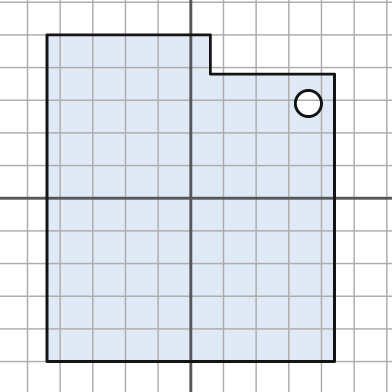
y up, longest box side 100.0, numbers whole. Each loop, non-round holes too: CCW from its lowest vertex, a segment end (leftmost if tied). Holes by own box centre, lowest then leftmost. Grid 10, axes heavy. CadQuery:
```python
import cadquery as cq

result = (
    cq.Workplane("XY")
    .moveTo(-44.0, -50.0)
    .lineTo(44.0, -50.0)
    .lineTo(44.0, 38.0)
    .lineTo(6.0, 38.0)
    .lineTo(6.0, 50.0)
    .lineTo(-44.0, 50.0)
    .close()
    .moveTo(36.0, 29.0)
    .circle(4.0)
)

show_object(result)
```